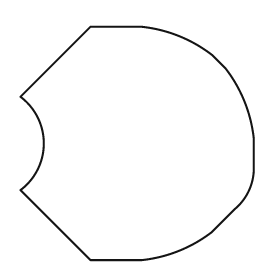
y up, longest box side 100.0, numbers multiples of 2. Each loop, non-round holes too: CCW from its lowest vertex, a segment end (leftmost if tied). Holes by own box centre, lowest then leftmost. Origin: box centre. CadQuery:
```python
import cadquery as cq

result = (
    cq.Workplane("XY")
    .moveTo(-20.0, -50.0)
    .lineTo(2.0, -50.0)
    .threePointArc((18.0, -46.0), (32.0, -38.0))
    .lineTo(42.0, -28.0)
    .threePointArc((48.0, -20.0), (50.0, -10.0))
    .lineTo(50.0, 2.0)
    .threePointArc((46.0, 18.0), (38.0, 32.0))
    .lineTo(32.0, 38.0)
    .threePointArc((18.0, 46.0), (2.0, 50.0))
    .lineTo(-20.0, 50.0)
    .lineTo(-50.0, 20.0)
    .threePointArc((-40.0, 0.0), (-50.0, -20.0))
    .close()
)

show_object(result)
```